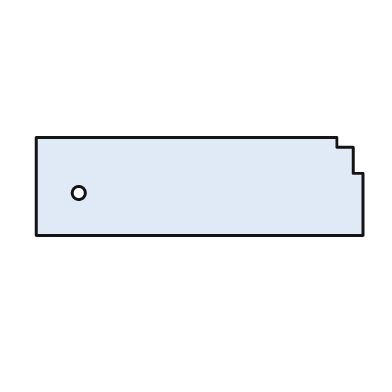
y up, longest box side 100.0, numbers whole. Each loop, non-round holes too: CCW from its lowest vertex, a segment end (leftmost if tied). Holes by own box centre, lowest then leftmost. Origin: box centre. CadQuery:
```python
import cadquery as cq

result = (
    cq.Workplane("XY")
    .moveTo(-50.0, -15.0)
    .lineTo(50.0, -15.0)
    .lineTo(50.0, 4.0)
    .lineTo(47.0, 4.0)
    .lineTo(47.0, 12.0)
    .lineTo(42.0, 12.0)
    .lineTo(42.0, 15.0)
    .lineTo(-50.0, 15.0)
    .close()
    .moveTo(-37.0, -2.0)
    .circle(2.0)
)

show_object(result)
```